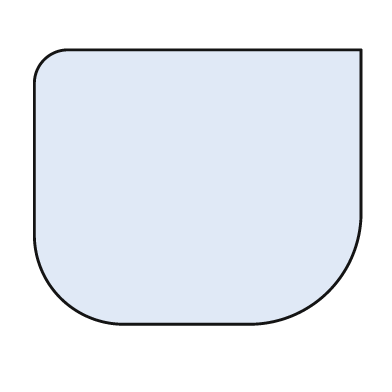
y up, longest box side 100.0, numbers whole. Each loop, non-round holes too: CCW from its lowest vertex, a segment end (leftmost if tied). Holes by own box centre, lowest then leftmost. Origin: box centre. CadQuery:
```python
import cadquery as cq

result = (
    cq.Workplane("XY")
    .moveTo(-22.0, -42.0)
    .lineTo(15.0, -42.0)
    .threePointArc((40.0, -32.0), (50.0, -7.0))
    .lineTo(50.0, 42.0)
    .lineTo(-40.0, 42.0)
    .threePointArc((-47.0, 39.0), (-50.0, 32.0))
    .lineTo(-50.0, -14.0)
    .threePointArc((-42.0, -34.0), (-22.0, -42.0))
    .close()
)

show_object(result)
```